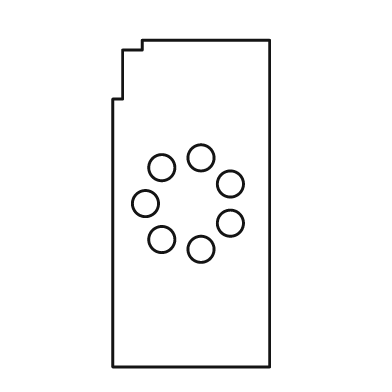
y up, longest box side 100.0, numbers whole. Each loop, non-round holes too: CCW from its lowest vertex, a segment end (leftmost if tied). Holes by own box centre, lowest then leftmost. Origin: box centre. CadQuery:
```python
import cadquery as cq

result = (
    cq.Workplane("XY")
    .moveTo(-24.0, -50.0)
    .lineTo(24.0, -50.0)
    .lineTo(24.0, 50.0)
    .lineTo(-15.0, 50.0)
    .lineTo(-15.0, 47.0)
    .lineTo(-21.0, 47.0)
    .lineTo(-21.0, 32.0)
    .lineTo(-24.0, 32.0)
    .close()
    .moveTo(3.0, -14.0)
    .circle(4.0)
    .moveTo(-9.0, -11.0)
    .circle(4.0)
    .moveTo(12.0, -6.0)
    .circle(4.0)
    .moveTo(-14.0, 0.0)
    .circle(4.0)
    .moveTo(12.0, 6.0)
    .circle(4.0)
    .moveTo(-9.0, 11.0)
    .circle(4.0)
    .moveTo(3.0, 14.0)
    .circle(4.0)
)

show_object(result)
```